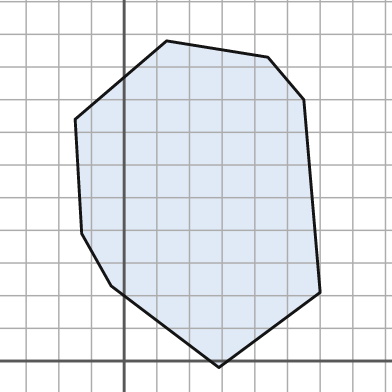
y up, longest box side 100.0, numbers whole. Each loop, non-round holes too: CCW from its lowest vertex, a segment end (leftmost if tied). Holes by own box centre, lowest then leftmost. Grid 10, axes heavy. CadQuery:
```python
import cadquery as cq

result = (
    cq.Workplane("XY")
    .moveTo(29.0, -2.0)
    .lineTo(60.0, 21.0)
    .lineTo(55.0, 80.0)
    .lineTo(44.0, 93.0)
    .lineTo(13.0, 98.0)
    .lineTo(-15.0, 74.0)
    .lineTo(-13.0, 39.0)
    .lineTo(-4.0, 23.0)
    .close()
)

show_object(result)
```